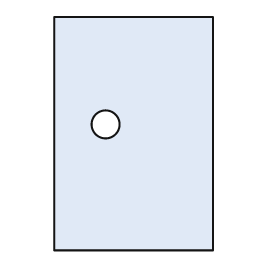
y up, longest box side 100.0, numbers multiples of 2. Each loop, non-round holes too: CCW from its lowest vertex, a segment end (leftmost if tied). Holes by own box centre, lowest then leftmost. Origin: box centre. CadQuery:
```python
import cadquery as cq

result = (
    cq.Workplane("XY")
    .moveTo(-34.0, -50.0)
    .lineTo(34.0, -50.0)
    .lineTo(34.0, 50.0)
    .lineTo(-34.0, 50.0)
    .close()
    .moveTo(-12.0, 4.0)
    .circle(6.0)
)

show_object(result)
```